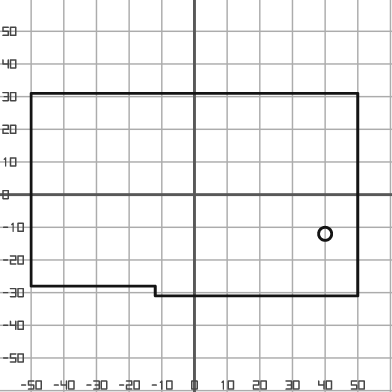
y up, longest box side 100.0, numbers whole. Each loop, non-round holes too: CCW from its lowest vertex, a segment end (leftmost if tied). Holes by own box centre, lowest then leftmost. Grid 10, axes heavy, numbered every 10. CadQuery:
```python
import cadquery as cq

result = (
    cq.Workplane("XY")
    .moveTo(-12.0, -31.0)
    .lineTo(50.0, -31.0)
    .lineTo(50.0, 31.0)
    .lineTo(-50.0, 31.0)
    .lineTo(-50.0, -28.0)
    .lineTo(-12.0, -28.0)
    .close()
    .moveTo(40.0, -12.0)
    .circle(2.0)
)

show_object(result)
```